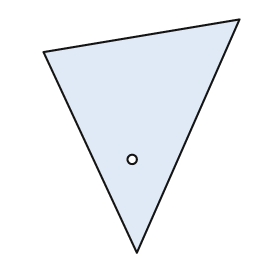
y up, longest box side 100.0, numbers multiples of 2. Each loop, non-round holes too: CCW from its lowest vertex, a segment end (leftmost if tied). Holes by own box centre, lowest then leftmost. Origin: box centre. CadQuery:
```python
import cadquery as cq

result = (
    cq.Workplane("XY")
    .moveTo(-2.0, -50.0)
    .lineTo(42.0, 50.0)
    .lineTo(-42.0, 36.0)
    .close()
    .moveTo(-4.0, -10.0)
    .circle(2.0)
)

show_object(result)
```